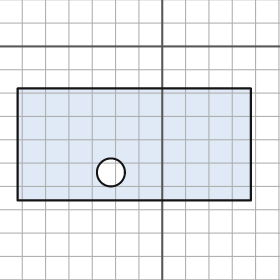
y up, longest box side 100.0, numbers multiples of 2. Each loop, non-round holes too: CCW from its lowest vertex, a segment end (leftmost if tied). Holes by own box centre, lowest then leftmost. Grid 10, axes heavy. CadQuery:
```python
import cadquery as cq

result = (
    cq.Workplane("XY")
    .moveTo(-62.0, -66.0)
    .lineTo(38.0, -66.0)
    .lineTo(38.0, -18.0)
    .lineTo(-62.0, -18.0)
    .close()
    .moveTo(-22.0, -54.0)
    .circle(6.0)
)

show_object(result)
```